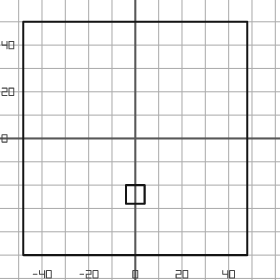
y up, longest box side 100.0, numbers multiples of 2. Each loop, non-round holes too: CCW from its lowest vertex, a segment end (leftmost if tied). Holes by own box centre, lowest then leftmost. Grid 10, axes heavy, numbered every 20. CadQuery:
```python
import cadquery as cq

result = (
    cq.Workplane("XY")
    .moveTo(-48.0, -50.0)
    .lineTo(48.0, -50.0)
    .lineTo(48.0, 50.0)
    .lineTo(-48.0, 50.0)
    .close()
    .moveTo(-4.0, -28.0)
    .lineTo(4.0, -28.0)
    .lineTo(4.0, -20.0)
    .lineTo(-4.0, -20.0)
    .close()
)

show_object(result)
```